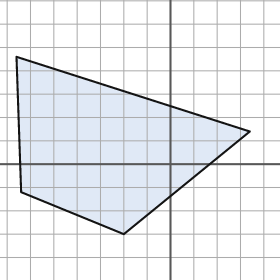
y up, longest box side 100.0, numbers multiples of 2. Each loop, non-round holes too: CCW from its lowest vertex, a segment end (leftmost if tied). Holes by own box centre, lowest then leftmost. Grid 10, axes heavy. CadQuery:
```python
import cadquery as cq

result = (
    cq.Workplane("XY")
    .moveTo(-20.0, -30.0)
    .lineTo(34.0, 14.0)
    .lineTo(-66.0, 46.0)
    .lineTo(-64.0, -12.0)
    .close()
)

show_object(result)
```